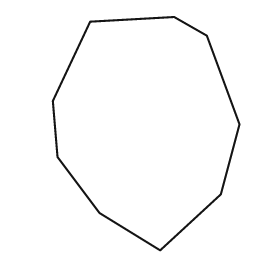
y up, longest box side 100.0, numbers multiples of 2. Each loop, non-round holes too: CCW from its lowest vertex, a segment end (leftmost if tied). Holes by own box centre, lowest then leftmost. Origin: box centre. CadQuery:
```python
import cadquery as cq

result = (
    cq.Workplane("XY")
    .moveTo(6.0, -50.0)
    .lineTo(32.0, -26.0)
    .lineTo(40.0, 4.0)
    .lineTo(26.0, 42.0)
    .lineTo(12.0, 50.0)
    .lineTo(-24.0, 48.0)
    .lineTo(-40.0, 14.0)
    .lineTo(-38.0, -10.0)
    .lineTo(-20.0, -34.0)
    .close()
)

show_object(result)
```